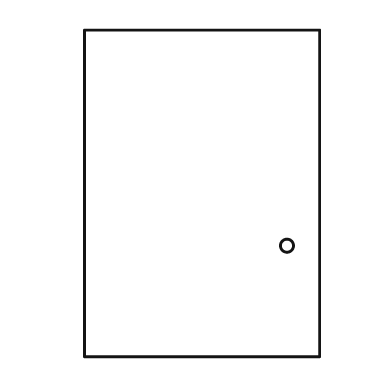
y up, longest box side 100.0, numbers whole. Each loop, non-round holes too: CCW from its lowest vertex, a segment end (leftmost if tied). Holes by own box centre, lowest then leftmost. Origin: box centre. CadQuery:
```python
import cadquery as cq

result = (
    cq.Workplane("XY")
    .moveTo(-36.0, -50.0)
    .lineTo(36.0, -50.0)
    .lineTo(36.0, 50.0)
    .lineTo(-36.0, 50.0)
    .close()
    .moveTo(26.0, -16.0)
    .circle(2.0)
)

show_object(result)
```